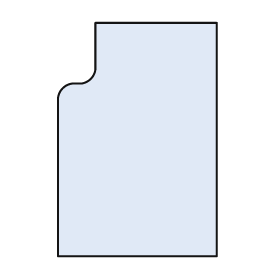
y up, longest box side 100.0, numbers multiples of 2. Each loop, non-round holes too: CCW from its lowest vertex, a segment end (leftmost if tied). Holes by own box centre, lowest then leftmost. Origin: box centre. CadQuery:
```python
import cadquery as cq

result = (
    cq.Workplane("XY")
    .moveTo(-34.0, -50.0)
    .lineTo(34.0, -50.0)
    .lineTo(34.0, 50.0)
    .lineTo(-18.0, 50.0)
    .lineTo(-18.0, 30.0)
    .threePointArc((-20.0, 26.0), (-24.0, 24.0))
    .lineTo(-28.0, 24.0)
    .threePointArc((-32.0, 22.0), (-34.0, 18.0))
    .close()
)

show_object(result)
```